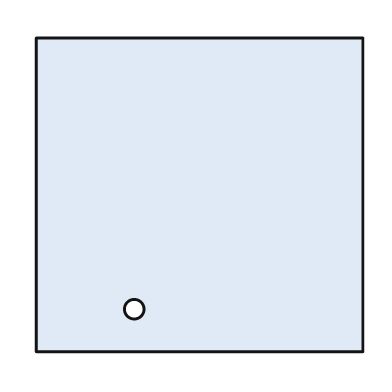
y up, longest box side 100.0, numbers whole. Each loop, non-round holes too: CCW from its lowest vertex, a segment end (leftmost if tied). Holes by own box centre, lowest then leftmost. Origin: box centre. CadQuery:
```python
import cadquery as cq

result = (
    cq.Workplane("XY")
    .moveTo(-50.0, -48.0)
    .lineTo(50.0, -48.0)
    .lineTo(50.0, 48.0)
    .lineTo(-50.0, 48.0)
    .close()
    .moveTo(-20.0, -35.0)
    .circle(3.0)
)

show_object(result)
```